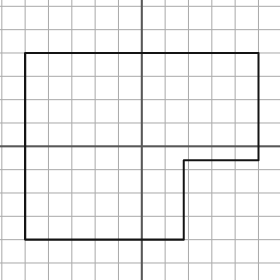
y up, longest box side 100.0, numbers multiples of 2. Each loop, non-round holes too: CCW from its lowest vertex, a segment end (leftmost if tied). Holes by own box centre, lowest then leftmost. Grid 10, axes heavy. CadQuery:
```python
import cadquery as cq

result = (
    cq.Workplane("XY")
    .moveTo(-50.0, -40.0)
    .lineTo(18.0, -40.0)
    .lineTo(18.0, -6.0)
    .lineTo(50.0, -6.0)
    .lineTo(50.0, 40.0)
    .lineTo(-50.0, 40.0)
    .close()
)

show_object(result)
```